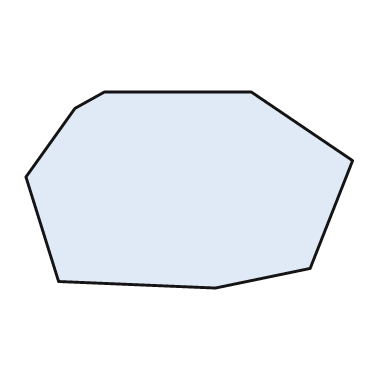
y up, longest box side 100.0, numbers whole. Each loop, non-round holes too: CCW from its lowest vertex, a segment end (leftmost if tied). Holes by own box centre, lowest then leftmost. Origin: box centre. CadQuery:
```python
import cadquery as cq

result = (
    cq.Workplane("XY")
    .moveTo(8.0, -30.0)
    .lineTo(37.0, -24.0)
    .lineTo(50.0, 9.0)
    .lineTo(19.0, 30.0)
    .lineTo(-26.0, 30.0)
    .lineTo(-35.0, 25.0)
    .lineTo(-50.0, 4.0)
    .lineTo(-40.0, -28.0)
    .close()
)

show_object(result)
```